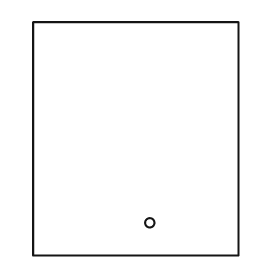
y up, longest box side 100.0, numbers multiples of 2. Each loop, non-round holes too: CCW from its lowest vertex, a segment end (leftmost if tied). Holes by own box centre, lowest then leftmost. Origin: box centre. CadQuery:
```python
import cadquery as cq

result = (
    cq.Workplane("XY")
    .moveTo(-44.0, -50.0)
    .lineTo(44.0, -50.0)
    .lineTo(44.0, 50.0)
    .lineTo(-44.0, 50.0)
    .close()
    .moveTo(6.0, -36.0)
    .circle(2.0)
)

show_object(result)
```